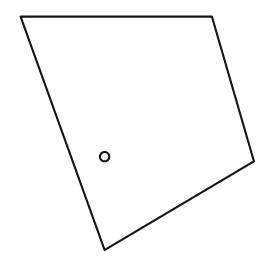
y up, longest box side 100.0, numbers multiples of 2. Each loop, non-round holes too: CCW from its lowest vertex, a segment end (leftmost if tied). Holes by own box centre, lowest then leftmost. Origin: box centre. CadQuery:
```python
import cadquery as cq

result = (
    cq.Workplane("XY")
    .moveTo(-14.0, -50.0)
    .lineTo(50.0, -12.0)
    .lineTo(32.0, 50.0)
    .lineTo(-50.0, 50.0)
    .close()
    .moveTo(-14.0, -10.0)
    .circle(2.0)
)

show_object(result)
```